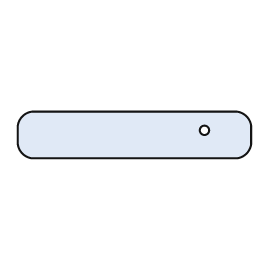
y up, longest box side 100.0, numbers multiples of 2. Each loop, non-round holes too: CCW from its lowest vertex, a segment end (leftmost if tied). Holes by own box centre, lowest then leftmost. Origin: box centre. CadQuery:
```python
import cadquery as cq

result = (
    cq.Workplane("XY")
    .moveTo(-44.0, -10.0)
    .lineTo(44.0, -10.0)
    .threePointArc((48.0, -8.0), (50.0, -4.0))
    .lineTo(50.0, 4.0)
    .threePointArc((48.0, 8.0), (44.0, 10.0))
    .lineTo(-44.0, 10.0)
    .threePointArc((-48.0, 8.0), (-50.0, 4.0))
    .lineTo(-50.0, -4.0)
    .threePointArc((-48.0, -8.0), (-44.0, -10.0))
    .close()
    .moveTo(30.0, 2.0)
    .circle(2.0)
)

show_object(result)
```